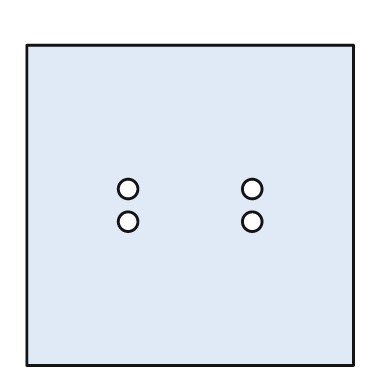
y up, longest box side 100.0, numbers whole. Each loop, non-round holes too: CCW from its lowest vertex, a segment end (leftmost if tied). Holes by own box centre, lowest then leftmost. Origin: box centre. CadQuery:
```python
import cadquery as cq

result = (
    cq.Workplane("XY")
    .moveTo(-50.0, -49.0)
    .lineTo(50.0, -49.0)
    .lineTo(50.0, 49.0)
    .lineTo(-50.0, 49.0)
    .close()
    .moveTo(-19.0, -5.0)
    .circle(3.0)
    .moveTo(19.0, -5.0)
    .circle(3.0)
    .moveTo(-19.0, 5.0)
    .circle(3.0)
    .moveTo(19.0, 5.0)
    .circle(3.0)
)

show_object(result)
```